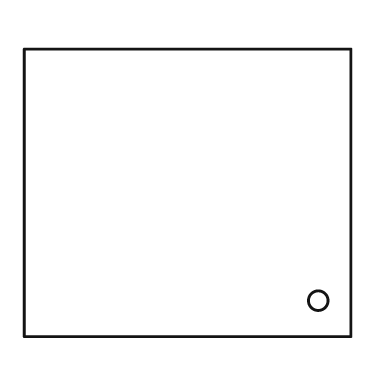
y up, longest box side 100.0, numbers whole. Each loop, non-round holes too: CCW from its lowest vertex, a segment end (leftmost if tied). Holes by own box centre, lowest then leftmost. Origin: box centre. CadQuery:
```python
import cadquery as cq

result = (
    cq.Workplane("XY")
    .moveTo(-50.0, -44.0)
    .lineTo(50.0, -44.0)
    .lineTo(50.0, 44.0)
    .lineTo(-50.0, 44.0)
    .close()
    .moveTo(40.0, -33.0)
    .circle(3.0)
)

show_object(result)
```